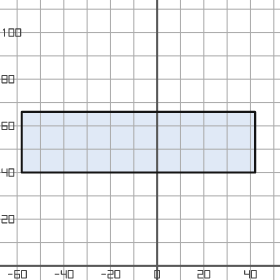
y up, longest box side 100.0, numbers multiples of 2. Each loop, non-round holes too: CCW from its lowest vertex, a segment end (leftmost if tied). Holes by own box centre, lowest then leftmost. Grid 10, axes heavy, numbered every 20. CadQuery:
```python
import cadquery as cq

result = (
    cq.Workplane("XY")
    .moveTo(-58.0, 40.0)
    .lineTo(42.0, 40.0)
    .lineTo(42.0, 66.0)
    .lineTo(-58.0, 66.0)
    .close()
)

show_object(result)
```